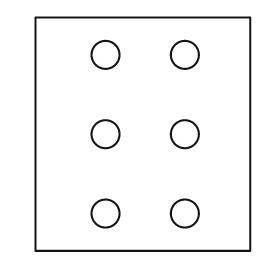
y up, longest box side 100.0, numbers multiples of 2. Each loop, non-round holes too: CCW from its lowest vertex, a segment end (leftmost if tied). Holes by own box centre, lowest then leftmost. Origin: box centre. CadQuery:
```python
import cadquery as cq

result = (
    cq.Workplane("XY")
    .moveTo(-46.0, -50.0)
    .lineTo(46.0, -50.0)
    .lineTo(46.0, 50.0)
    .lineTo(-46.0, 50.0)
    .close()
    .moveTo(-16.0, -34.0)
    .circle(6.0)
    .moveTo(18.0, -34.0)
    .circle(6.0)
    .moveTo(-16.0, 0.0)
    .circle(6.0)
    .moveTo(18.0, 0.0)
    .circle(6.0)
    .moveTo(-16.0, 34.0)
    .circle(6.0)
    .moveTo(18.0, 34.0)
    .circle(6.0)
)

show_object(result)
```